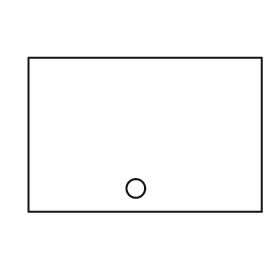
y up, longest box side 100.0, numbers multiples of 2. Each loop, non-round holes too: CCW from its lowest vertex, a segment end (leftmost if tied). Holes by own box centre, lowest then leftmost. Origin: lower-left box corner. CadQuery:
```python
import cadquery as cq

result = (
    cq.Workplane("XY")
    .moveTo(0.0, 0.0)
    .lineTo(100.0, 0.0)
    .lineTo(100.0, 66.0)
    .lineTo(0.0, 66.0)
    .close()
    .moveTo(46.0, 10.0)
    .circle(4.0)
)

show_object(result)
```